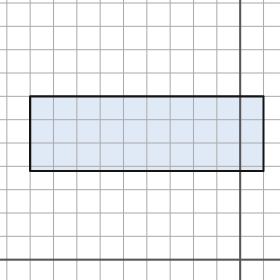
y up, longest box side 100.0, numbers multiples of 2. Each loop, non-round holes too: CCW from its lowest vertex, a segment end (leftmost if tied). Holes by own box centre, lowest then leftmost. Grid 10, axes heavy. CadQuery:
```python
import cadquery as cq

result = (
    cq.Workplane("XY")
    .moveTo(-90.0, 38.0)
    .lineTo(10.0, 38.0)
    .lineTo(10.0, 70.0)
    .lineTo(-90.0, 70.0)
    .close()
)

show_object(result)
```